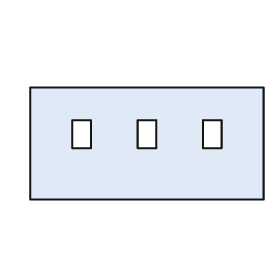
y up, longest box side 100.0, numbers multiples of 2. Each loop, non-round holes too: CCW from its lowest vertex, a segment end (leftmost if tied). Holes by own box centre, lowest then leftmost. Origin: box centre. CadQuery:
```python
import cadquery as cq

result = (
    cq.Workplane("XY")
    .moveTo(-50.0, -24.0)
    .lineTo(50.0, -24.0)
    .lineTo(50.0, 24.0)
    .lineTo(-50.0, 24.0)
    .close()
    .moveTo(-32.0, -2.0)
    .lineTo(-24.0, -2.0)
    .lineTo(-24.0, 10.0)
    .lineTo(-32.0, 10.0)
    .close()
    .moveTo(-4.0, -2.0)
    .lineTo(4.0, -2.0)
    .lineTo(4.0, 10.0)
    .lineTo(-4.0, 10.0)
    .close()
    .moveTo(24.0, -2.0)
    .lineTo(32.0, -2.0)
    .lineTo(32.0, 10.0)
    .lineTo(24.0, 10.0)
    .close()
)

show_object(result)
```